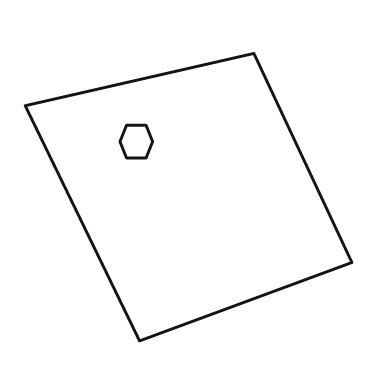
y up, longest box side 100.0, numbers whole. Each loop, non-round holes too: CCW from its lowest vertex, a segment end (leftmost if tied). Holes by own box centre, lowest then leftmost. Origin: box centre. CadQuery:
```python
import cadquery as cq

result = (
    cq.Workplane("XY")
    .moveTo(-15.0, -44.0)
    .lineTo(50.0, -20.0)
    .lineTo(20.0, 44.0)
    .lineTo(-50.0, 28.0)
    .close()
    .moveTo(-19.0, 12.0)
    .lineTo(-13.0, 12.0)
    .lineTo(-11.0, 17.0)
    .lineTo(-13.0, 22.0)
    .lineTo(-19.0, 22.0)
    .lineTo(-21.0, 17.0)
    .close()
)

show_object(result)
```